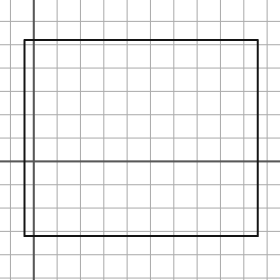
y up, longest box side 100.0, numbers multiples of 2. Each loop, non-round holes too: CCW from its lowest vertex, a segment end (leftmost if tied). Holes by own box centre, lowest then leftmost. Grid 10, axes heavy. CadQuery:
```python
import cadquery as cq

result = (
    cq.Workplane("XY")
    .moveTo(-4.0, -32.0)
    .lineTo(96.0, -32.0)
    .lineTo(96.0, 52.0)
    .lineTo(-4.0, 52.0)
    .close()
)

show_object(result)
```